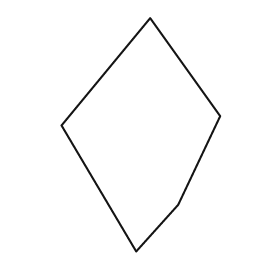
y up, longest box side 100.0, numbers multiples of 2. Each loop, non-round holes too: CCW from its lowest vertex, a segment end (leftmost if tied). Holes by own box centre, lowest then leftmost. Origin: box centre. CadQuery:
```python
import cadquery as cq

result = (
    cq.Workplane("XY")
    .moveTo(-2.0, -50.0)
    .lineTo(16.0, -30.0)
    .lineTo(34.0, 8.0)
    .lineTo(4.0, 50.0)
    .lineTo(-34.0, 4.0)
    .close()
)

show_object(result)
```